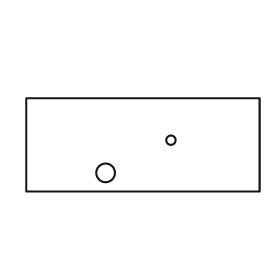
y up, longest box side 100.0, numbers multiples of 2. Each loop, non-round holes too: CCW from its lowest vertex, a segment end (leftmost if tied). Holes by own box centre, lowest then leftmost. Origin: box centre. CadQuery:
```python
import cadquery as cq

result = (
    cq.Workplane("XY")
    .moveTo(-50.0, -20.0)
    .lineTo(50.0, -20.0)
    .lineTo(50.0, 20.0)
    .lineTo(-50.0, 20.0)
    .close()
    .moveTo(-16.0, -12.0)
    .circle(4.0)
    .moveTo(12.0, 2.0)
    .circle(2.0)
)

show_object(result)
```